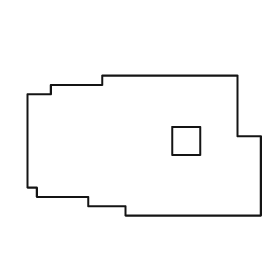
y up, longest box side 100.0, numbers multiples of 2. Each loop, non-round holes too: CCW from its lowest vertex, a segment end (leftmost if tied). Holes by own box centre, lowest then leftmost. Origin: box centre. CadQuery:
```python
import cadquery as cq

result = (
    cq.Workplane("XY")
    .moveTo(-8.0, -30.0)
    .lineTo(50.0, -30.0)
    .lineTo(50.0, 4.0)
    .lineTo(40.0, 4.0)
    .lineTo(40.0, 30.0)
    .lineTo(-18.0, 30.0)
    .lineTo(-18.0, 26.0)
    .lineTo(-40.0, 26.0)
    .lineTo(-40.0, 22.0)
    .lineTo(-50.0, 22.0)
    .lineTo(-50.0, -18.0)
    .lineTo(-46.0, -18.0)
    .lineTo(-46.0, -22.0)
    .lineTo(-24.0, -22.0)
    .lineTo(-24.0, -26.0)
    .lineTo(-8.0, -26.0)
    .close()
    .moveTo(12.0, -4.0)
    .lineTo(24.0, -4.0)
    .lineTo(24.0, 8.0)
    .lineTo(12.0, 8.0)
    .close()
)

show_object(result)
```